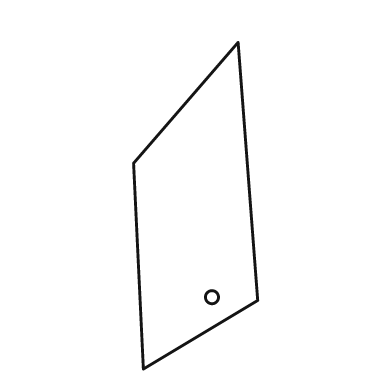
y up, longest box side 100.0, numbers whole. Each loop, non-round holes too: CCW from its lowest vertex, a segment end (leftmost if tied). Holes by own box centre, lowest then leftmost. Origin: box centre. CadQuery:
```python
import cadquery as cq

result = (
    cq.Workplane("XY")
    .moveTo(-16.0, -50.0)
    .lineTo(19.0, -29.0)
    .lineTo(13.0, 50.0)
    .lineTo(-19.0, 13.0)
    .close()
    .moveTo(5.0, -28.0)
    .circle(2.0)
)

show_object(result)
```